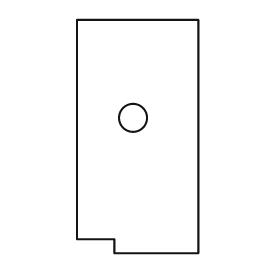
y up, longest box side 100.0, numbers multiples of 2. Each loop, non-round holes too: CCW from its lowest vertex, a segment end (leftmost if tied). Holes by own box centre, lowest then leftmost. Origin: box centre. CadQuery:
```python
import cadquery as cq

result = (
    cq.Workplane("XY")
    .moveTo(-10.0, -50.0)
    .lineTo(26.0, -50.0)
    .lineTo(26.0, 50.0)
    .lineTo(-26.0, 50.0)
    .lineTo(-26.0, -44.0)
    .lineTo(-10.0, -44.0)
    .close()
    .moveTo(-2.0, 8.0)
    .circle(6.0)
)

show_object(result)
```